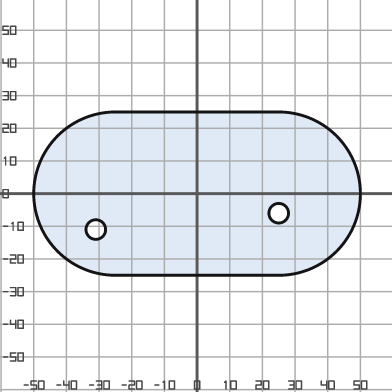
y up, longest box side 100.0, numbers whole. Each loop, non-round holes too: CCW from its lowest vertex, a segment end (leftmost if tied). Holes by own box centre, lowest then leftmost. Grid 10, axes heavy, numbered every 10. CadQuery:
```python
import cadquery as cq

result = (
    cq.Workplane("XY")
    .moveTo(-25.0, -25.0)
    .lineTo(25.0, -25.0)
    .threePointArc((50.0, 0.0), (25.0, 25.0))
    .lineTo(-25.0, 25.0)
    .threePointArc((-50.0, 0.0), (-25.0, -25.0))
    .close()
    .moveTo(-31.0, -11.0)
    .circle(3.0)
    .moveTo(25.0, -6.0)
    .circle(3.0)
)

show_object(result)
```